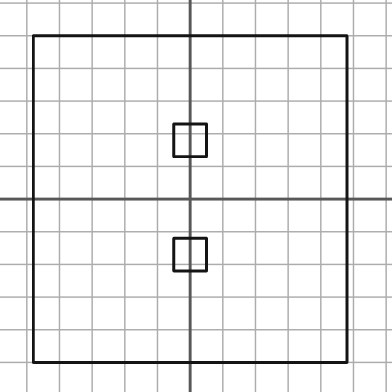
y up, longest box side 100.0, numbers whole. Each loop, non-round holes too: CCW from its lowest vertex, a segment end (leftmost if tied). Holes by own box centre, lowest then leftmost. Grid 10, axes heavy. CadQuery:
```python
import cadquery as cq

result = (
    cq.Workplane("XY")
    .moveTo(-48.0, -50.0)
    .lineTo(48.0, -50.0)
    .lineTo(48.0, 50.0)
    .lineTo(-48.0, 50.0)
    .close()
    .moveTo(-5.0, -22.0)
    .lineTo(5.0, -22.0)
    .lineTo(5.0, -12.0)
    .lineTo(-5.0, -12.0)
    .close()
    .moveTo(-5.0, 13.0)
    .lineTo(5.0, 13.0)
    .lineTo(5.0, 23.0)
    .lineTo(-5.0, 23.0)
    .close()
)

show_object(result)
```